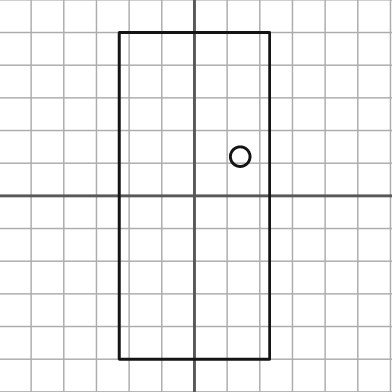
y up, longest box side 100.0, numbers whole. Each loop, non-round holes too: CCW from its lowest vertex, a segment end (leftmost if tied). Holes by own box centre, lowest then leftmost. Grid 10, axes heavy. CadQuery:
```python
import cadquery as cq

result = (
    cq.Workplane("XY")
    .moveTo(-23.0, -50.0)
    .lineTo(23.0, -50.0)
    .lineTo(23.0, 50.0)
    .lineTo(-23.0, 50.0)
    .close()
    .moveTo(14.0, 12.0)
    .circle(3.0)
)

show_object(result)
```